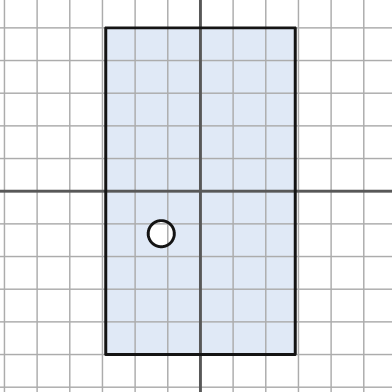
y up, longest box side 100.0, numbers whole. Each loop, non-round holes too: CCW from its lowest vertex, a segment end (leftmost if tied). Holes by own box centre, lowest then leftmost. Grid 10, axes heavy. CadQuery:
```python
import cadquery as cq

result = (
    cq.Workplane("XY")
    .moveTo(-29.0, -50.0)
    .lineTo(29.0, -50.0)
    .lineTo(29.0, 50.0)
    .lineTo(-29.0, 50.0)
    .close()
    .moveTo(-12.0, -13.0)
    .circle(4.0)
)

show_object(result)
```